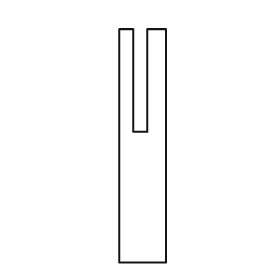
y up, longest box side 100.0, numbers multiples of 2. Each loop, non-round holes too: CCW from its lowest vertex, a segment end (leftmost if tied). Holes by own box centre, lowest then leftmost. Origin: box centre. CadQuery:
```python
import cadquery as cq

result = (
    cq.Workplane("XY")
    .moveTo(-10.0, -50.0)
    .lineTo(10.0, -50.0)
    .lineTo(10.0, 50.0)
    .lineTo(2.0, 50.0)
    .lineTo(2.0, 6.0)
    .lineTo(-4.0, 6.0)
    .lineTo(-4.0, 50.0)
    .lineTo(-10.0, 50.0)
    .close()
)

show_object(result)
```